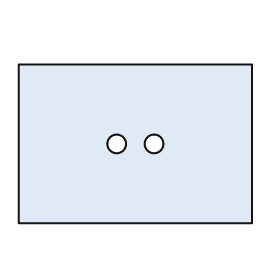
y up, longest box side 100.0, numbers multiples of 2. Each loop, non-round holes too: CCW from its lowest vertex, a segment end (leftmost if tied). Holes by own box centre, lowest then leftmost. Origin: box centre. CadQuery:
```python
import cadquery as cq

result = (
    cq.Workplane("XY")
    .moveTo(-50.0, -34.0)
    .lineTo(50.0, -34.0)
    .lineTo(50.0, 34.0)
    .lineTo(-50.0, 34.0)
    .close()
    .moveTo(-8.0, 0.0)
    .circle(4.0)
    .moveTo(8.0, 0.0)
    .circle(4.0)
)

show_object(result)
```